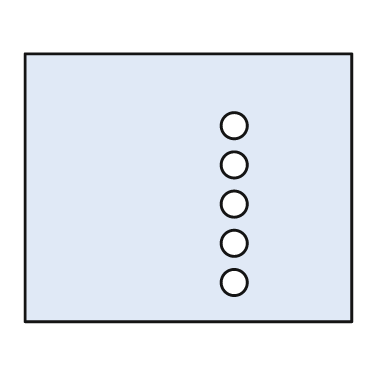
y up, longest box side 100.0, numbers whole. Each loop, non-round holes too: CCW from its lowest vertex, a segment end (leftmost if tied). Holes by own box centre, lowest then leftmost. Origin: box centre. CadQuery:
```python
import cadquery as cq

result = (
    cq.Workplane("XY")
    .moveTo(-50.0, -41.0)
    .lineTo(50.0, -41.0)
    .lineTo(50.0, 41.0)
    .lineTo(-50.0, 41.0)
    .close()
    .moveTo(14.0, -29.0)
    .circle(4.0)
    .moveTo(14.0, -17.0)
    .circle(4.0)
    .moveTo(14.0, -5.0)
    .circle(4.0)
    .moveTo(14.0, 7.0)
    .circle(4.0)
    .moveTo(14.0, 19.0)
    .circle(4.0)
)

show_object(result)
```